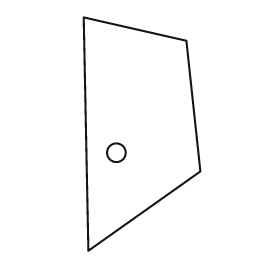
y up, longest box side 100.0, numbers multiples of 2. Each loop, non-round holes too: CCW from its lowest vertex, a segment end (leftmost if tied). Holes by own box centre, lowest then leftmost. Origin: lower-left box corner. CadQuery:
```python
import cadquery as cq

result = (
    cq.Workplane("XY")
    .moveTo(2.0, 0.0)
    .lineTo(50.0, 34.0)
    .lineTo(44.0, 90.0)
    .lineTo(0.0, 100.0)
    .close()
    .moveTo(14.0, 42.0)
    .circle(4.0)
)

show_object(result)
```